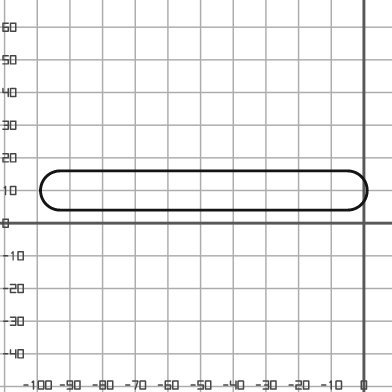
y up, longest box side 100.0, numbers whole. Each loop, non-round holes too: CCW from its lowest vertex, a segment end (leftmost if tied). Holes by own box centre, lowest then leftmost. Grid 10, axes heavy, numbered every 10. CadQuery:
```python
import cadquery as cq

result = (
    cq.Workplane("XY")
    .moveTo(-93.0, 4.0)
    .lineTo(-5.0, 4.0)
    .threePointArc((1.0, 10.0), (-5.0, 16.0))
    .lineTo(-93.0, 16.0)
    .threePointArc((-99.0, 10.0), (-93.0, 4.0))
    .close()
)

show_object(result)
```